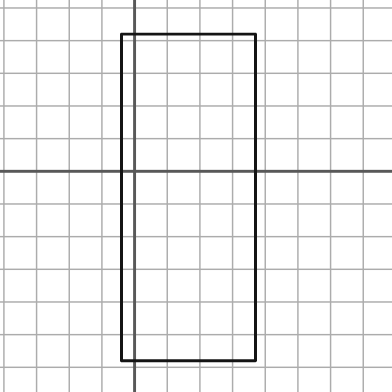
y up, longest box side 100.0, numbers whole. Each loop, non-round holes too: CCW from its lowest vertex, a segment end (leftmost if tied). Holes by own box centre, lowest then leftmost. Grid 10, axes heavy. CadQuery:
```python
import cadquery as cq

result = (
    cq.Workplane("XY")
    .moveTo(-4.0, -58.0)
    .lineTo(37.0, -58.0)
    .lineTo(37.0, 42.0)
    .lineTo(-4.0, 42.0)
    .close()
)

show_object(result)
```